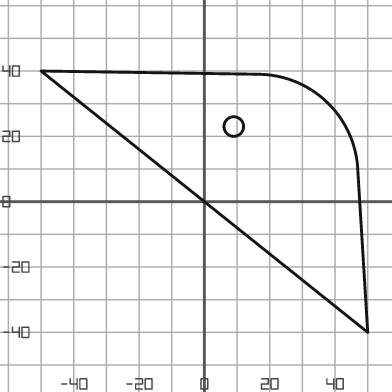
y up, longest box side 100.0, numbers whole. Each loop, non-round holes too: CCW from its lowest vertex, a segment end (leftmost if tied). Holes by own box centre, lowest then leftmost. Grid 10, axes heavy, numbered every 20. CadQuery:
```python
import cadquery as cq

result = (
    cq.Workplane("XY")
    .moveTo(50.0, -40.0)
    .lineTo(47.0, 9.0)
    .threePointArc((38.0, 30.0), (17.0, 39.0))
    .lineTo(-50.0, 40.0)
    .close()
    .moveTo(9.0, 23.0)
    .circle(3.0)
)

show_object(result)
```